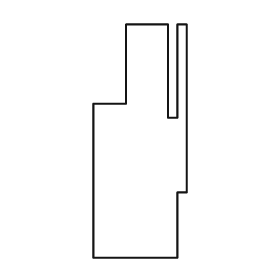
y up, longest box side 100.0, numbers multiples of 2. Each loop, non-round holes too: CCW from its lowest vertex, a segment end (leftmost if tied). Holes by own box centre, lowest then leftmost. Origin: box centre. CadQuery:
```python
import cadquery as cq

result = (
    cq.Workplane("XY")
    .moveTo(-20.0, -50.0)
    .lineTo(16.0, -50.0)
    .lineTo(16.0, -22.0)
    .lineTo(20.0, -22.0)
    .lineTo(20.0, 50.0)
    .lineTo(16.0, 50.0)
    .lineTo(16.0, 10.0)
    .lineTo(12.0, 10.0)
    .lineTo(12.0, 50.0)
    .lineTo(-6.0, 50.0)
    .lineTo(-6.0, 16.0)
    .lineTo(-20.0, 16.0)
    .close()
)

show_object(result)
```